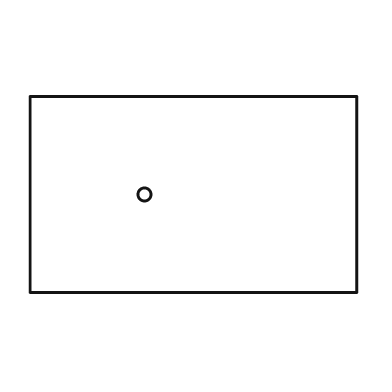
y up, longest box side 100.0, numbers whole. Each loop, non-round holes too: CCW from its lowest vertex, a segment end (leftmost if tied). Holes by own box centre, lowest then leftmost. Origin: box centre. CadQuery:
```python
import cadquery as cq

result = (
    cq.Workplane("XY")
    .moveTo(-50.0, -30.0)
    .lineTo(50.0, -30.0)
    .lineTo(50.0, 30.0)
    .lineTo(-50.0, 30.0)
    .close()
    .moveTo(-15.0, 0.0)
    .circle(2.0)
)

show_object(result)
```